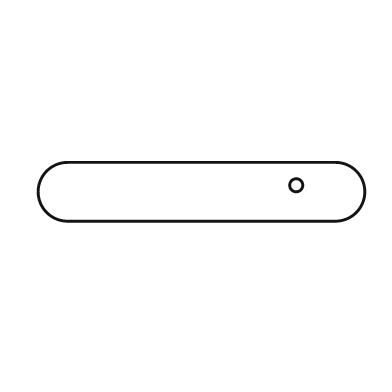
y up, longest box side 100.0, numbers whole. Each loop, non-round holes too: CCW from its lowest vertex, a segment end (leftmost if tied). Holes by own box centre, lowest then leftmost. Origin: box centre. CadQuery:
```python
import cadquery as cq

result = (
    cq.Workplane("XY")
    .moveTo(-41.0, -9.0)
    .lineTo(41.0, -9.0)
    .threePointArc((50.0, 0.0), (41.0, 9.0))
    .lineTo(-41.0, 9.0)
    .threePointArc((-50.0, 0.0), (-41.0, -9.0))
    .close()
    .moveTo(29.0, 2.0)
    .circle(2.0)
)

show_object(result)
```